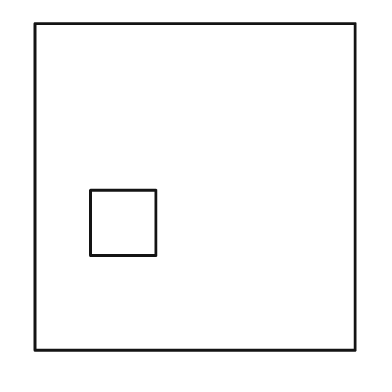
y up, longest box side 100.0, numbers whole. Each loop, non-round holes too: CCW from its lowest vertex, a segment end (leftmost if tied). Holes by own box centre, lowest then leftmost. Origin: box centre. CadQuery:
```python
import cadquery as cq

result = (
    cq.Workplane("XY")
    .moveTo(-49.0, -50.0)
    .lineTo(49.0, -50.0)
    .lineTo(49.0, 50.0)
    .lineTo(-49.0, 50.0)
    .close()
    .moveTo(-32.0, -21.0)
    .lineTo(-12.0, -21.0)
    .lineTo(-12.0, -1.0)
    .lineTo(-32.0, -1.0)
    .close()
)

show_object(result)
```